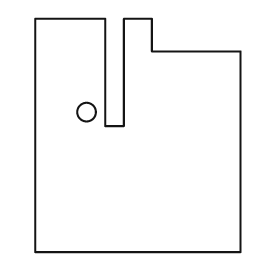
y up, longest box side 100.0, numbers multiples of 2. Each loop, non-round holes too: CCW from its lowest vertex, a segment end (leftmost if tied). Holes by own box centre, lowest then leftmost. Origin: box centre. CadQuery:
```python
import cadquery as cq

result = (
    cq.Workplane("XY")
    .moveTo(-44.0, -50.0)
    .lineTo(44.0, -50.0)
    .lineTo(44.0, 36.0)
    .lineTo(6.0, 36.0)
    .lineTo(6.0, 50.0)
    .lineTo(-6.0, 50.0)
    .lineTo(-6.0, 4.0)
    .lineTo(-14.0, 4.0)
    .lineTo(-14.0, 50.0)
    .lineTo(-44.0, 50.0)
    .close()
    .moveTo(-22.0, 10.0)
    .circle(4.0)
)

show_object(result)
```